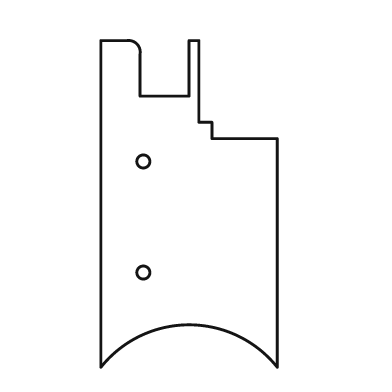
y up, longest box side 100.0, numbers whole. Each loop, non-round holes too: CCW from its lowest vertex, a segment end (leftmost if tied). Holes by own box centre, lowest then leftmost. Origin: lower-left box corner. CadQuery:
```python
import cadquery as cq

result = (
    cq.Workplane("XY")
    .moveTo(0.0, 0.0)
    .threePointArc((27.0, 13.0), (54.0, 0.0))
    .lineTo(54.0, 70.0)
    .lineTo(34.0, 70.0)
    .lineTo(34.0, 75.0)
    .lineTo(30.0, 75.0)
    .lineTo(30.0, 100.0)
    .lineTo(27.0, 100.0)
    .lineTo(27.0, 83.0)
    .lineTo(12.0, 83.0)
    .lineTo(12.0, 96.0)
    .threePointArc((11.0, 99.0), (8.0, 100.0))
    .lineTo(0.0, 100.0)
    .close()
    .moveTo(13.0, 29.0)
    .circle(2.0)
    .moveTo(13.0, 63.0)
    .circle(2.0)
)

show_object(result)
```